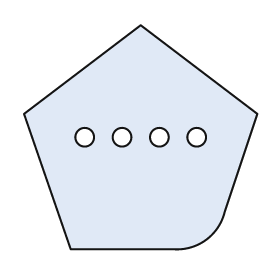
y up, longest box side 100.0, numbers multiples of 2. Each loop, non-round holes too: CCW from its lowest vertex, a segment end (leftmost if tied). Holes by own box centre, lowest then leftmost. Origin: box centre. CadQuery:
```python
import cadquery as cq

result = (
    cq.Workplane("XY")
    .moveTo(-30.0, -48.0)
    .lineTo(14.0, -48.0)
    .threePointArc((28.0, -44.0), (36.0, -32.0))
    .lineTo(50.0, 10.0)
    .lineTo(0.0, 48.0)
    .lineTo(-50.0, 10.0)
    .close()
    .moveTo(-24.0, 0.0)
    .circle(4.0)
    .moveTo(-8.0, 0.0)
    .circle(4.0)
    .moveTo(8.0, 0.0)
    .circle(4.0)
    .moveTo(24.0, 0.0)
    .circle(4.0)
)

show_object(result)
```